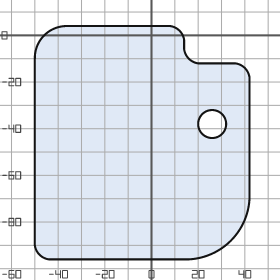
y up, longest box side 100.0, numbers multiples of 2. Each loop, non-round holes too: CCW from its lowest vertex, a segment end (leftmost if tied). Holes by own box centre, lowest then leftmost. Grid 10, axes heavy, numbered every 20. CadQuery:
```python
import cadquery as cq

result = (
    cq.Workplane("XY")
    .moveTo(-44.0, -96.0)
    .lineTo(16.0, -96.0)
    .threePointArc((34.0, -88.0), (42.0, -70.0))
    .lineTo(42.0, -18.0)
    .threePointArc((40.0, -14.0), (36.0, -12.0))
    .lineTo(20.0, -12.0)
    .threePointArc((16.0, -10.0), (14.0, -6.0))
    .lineTo(14.0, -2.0)
    .threePointArc((12.0, 2.0), (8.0, 4.0))
    .lineTo(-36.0, 4.0)
    .threePointArc((-46.0, 0.0), (-50.0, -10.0))
    .lineTo(-50.0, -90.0)
    .threePointArc((-48.0, -94.0), (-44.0, -96.0))
    .close()
    .moveTo(26.0, -38.0)
    .circle(6.0)
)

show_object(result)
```